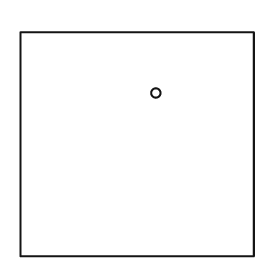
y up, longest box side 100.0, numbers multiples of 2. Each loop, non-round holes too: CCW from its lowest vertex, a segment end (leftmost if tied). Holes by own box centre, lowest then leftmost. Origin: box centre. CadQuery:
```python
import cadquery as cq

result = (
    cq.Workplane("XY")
    .moveTo(-50.0, -48.0)
    .lineTo(50.0, -48.0)
    .lineTo(50.0, 48.0)
    .lineTo(-50.0, 48.0)
    .close()
    .moveTo(8.0, 22.0)
    .circle(2.0)
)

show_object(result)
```